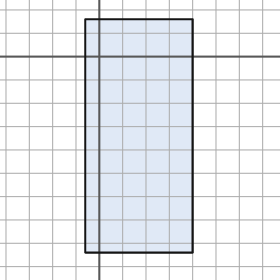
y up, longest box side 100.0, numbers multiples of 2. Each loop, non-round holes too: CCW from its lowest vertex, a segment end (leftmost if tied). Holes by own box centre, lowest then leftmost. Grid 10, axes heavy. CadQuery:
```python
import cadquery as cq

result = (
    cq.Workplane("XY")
    .moveTo(-6.0, -84.0)
    .lineTo(40.0, -84.0)
    .lineTo(40.0, 16.0)
    .lineTo(-6.0, 16.0)
    .close()
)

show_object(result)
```